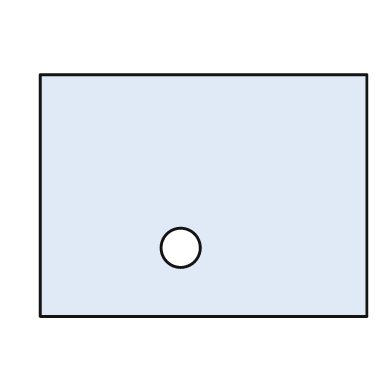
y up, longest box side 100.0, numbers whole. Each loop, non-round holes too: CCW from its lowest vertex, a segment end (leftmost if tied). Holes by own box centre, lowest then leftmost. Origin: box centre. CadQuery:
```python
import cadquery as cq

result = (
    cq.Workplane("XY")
    .moveTo(-50.0, -37.0)
    .lineTo(50.0, -37.0)
    .lineTo(50.0, 37.0)
    .lineTo(-50.0, 37.0)
    .close()
    .moveTo(-7.0, -16.0)
    .circle(6.0)
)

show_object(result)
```